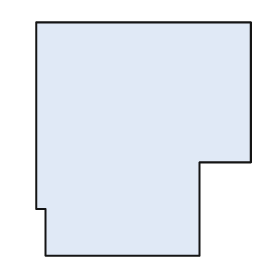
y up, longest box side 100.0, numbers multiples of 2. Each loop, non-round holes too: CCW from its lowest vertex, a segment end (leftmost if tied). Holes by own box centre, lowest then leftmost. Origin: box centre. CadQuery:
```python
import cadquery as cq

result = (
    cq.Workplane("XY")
    .moveTo(-42.0, -50.0)
    .lineTo(24.0, -50.0)
    .lineTo(24.0, -10.0)
    .lineTo(46.0, -10.0)
    .lineTo(46.0, 50.0)
    .lineTo(-46.0, 50.0)
    .lineTo(-46.0, -30.0)
    .lineTo(-42.0, -30.0)
    .close()
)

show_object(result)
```